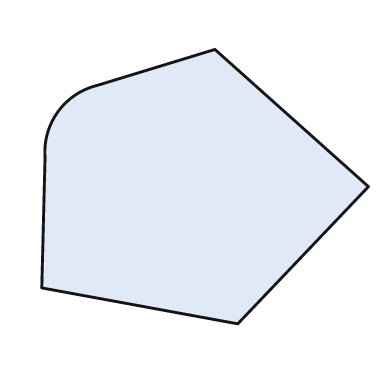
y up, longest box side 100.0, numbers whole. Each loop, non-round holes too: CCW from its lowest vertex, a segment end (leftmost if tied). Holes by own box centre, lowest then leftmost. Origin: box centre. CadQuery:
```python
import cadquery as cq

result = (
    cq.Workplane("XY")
    .moveTo(10.0, -42.0)
    .lineTo(50.0, 0.0)
    .lineTo(3.0, 42.0)
    .lineTo(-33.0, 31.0)
    .threePointArc((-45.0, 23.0), (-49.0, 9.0))
    .lineTo(-50.0, -31.0)
    .close()
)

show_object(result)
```